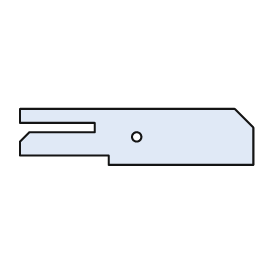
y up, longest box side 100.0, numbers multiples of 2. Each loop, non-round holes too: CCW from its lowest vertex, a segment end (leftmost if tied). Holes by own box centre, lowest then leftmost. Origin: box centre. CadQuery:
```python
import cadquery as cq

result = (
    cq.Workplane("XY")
    .moveTo(-12.0, -12.0)
    .lineTo(50.0, -12.0)
    .lineTo(50.0, 4.0)
    .lineTo(42.0, 12.0)
    .lineTo(-50.0, 12.0)
    .lineTo(-50.0, 6.0)
    .lineTo(-18.0, 6.0)
    .lineTo(-18.0, 2.0)
    .lineTo(-46.0, 2.0)
    .lineTo(-50.0, -2.0)
    .lineTo(-50.0, -8.0)
    .lineTo(-12.0, -8.0)
    .close()
    .moveTo(0.0, 0.0)
    .circle(2.0)
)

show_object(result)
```